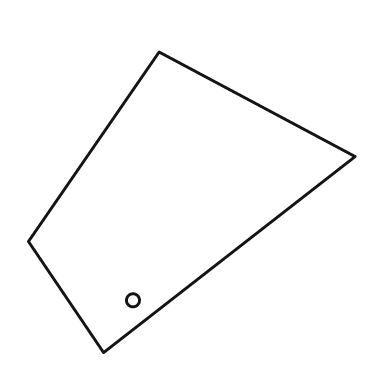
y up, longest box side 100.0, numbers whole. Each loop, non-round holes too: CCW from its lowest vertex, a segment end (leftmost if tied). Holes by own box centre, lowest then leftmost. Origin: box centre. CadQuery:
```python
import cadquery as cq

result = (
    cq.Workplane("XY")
    .moveTo(-27.0, -46.0)
    .lineTo(50.0, 14.0)
    .lineTo(-10.0, 46.0)
    .lineTo(-50.0, -12.0)
    .close()
    .moveTo(-18.0, -30.0)
    .circle(2.0)
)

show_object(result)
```